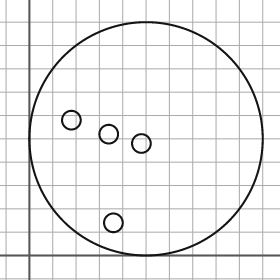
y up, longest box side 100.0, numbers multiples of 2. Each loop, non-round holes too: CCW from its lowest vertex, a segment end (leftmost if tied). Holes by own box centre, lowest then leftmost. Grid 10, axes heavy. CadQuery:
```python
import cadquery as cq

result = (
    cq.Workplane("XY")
    .moveTo(50.0, 50.0)
    .circle(50.0)
    .moveTo(36.0, 14.0)
    .circle(4.0)
    .moveTo(48.0, 48.0)
    .circle(4.0)
    .moveTo(34.0, 52.0)
    .circle(4.0)
    .moveTo(18.0, 58.0)
    .circle(4.0)
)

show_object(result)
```